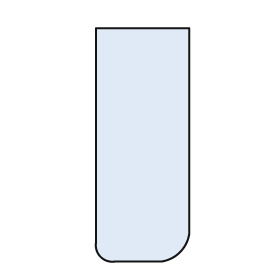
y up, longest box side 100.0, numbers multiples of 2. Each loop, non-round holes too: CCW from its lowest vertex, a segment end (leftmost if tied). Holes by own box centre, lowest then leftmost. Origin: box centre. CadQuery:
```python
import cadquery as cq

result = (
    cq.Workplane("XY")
    .moveTo(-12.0, -50.0)
    .lineTo(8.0, -50.0)
    .threePointArc((16.0, -46.0), (20.0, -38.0))
    .lineTo(20.0, 50.0)
    .lineTo(-20.0, 50.0)
    .lineTo(-20.0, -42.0)
    .threePointArc((-18.0, -48.0), (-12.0, -50.0))
    .close()
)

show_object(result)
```